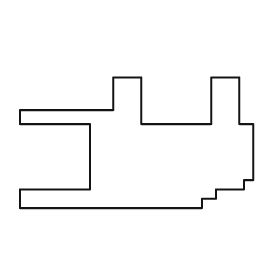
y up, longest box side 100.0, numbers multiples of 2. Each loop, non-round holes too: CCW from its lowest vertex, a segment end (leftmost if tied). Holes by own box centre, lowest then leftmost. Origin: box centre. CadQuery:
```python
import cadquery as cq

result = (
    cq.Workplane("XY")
    .moveTo(-50.0, -28.0)
    .lineTo(28.0, -28.0)
    .lineTo(28.0, -24.0)
    .lineTo(34.0, -24.0)
    .lineTo(34.0, -20.0)
    .lineTo(46.0, -20.0)
    .lineTo(46.0, -16.0)
    .lineTo(50.0, -16.0)
    .lineTo(50.0, 8.0)
    .lineTo(44.0, 8.0)
    .lineTo(44.0, 28.0)
    .lineTo(32.0, 28.0)
    .lineTo(32.0, 8.0)
    .lineTo(2.0, 8.0)
    .lineTo(2.0, 28.0)
    .lineTo(-10.0, 28.0)
    .lineTo(-10.0, 14.0)
    .lineTo(-50.0, 14.0)
    .lineTo(-50.0, 8.0)
    .lineTo(-20.0, 8.0)
    .lineTo(-20.0, -20.0)
    .lineTo(-50.0, -20.0)
    .close()
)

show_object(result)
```